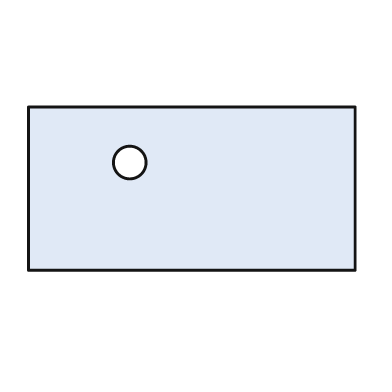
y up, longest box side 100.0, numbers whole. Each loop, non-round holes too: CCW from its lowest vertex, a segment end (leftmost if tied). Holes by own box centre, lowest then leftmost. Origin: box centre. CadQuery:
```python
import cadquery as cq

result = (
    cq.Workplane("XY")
    .moveTo(-50.0, -25.0)
    .lineTo(50.0, -25.0)
    .lineTo(50.0, 25.0)
    .lineTo(-50.0, 25.0)
    .close()
    .moveTo(-19.0, 8.0)
    .circle(5.0)
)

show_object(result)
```